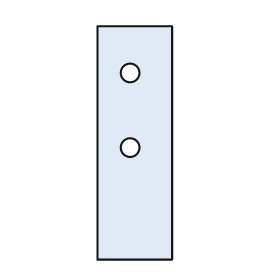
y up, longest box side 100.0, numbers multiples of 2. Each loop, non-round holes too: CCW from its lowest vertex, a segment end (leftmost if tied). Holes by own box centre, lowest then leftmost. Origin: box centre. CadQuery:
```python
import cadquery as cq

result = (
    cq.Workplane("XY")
    .moveTo(-16.0, -50.0)
    .lineTo(16.0, -50.0)
    .lineTo(16.0, 50.0)
    .lineTo(-16.0, 50.0)
    .close()
    .moveTo(-2.0, -2.0)
    .circle(4.0)
    .moveTo(-2.0, 30.0)
    .circle(4.0)
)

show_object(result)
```